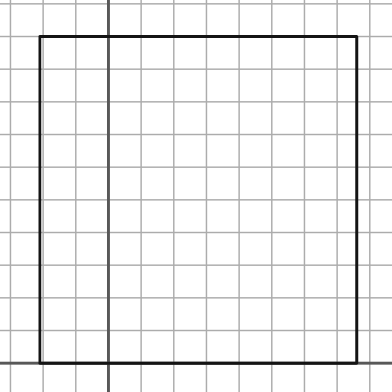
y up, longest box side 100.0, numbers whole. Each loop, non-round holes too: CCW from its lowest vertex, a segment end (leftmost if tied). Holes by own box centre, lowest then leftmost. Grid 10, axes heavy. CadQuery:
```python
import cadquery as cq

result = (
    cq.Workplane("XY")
    .moveTo(-21.0, 0.0)
    .lineTo(76.0, 0.0)
    .lineTo(76.0, 100.0)
    .lineTo(-21.0, 100.0)
    .close()
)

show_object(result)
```